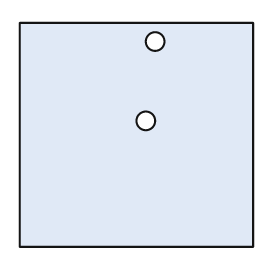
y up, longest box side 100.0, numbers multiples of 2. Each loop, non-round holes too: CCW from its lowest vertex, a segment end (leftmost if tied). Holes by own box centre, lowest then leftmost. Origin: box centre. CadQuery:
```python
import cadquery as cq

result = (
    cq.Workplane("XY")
    .moveTo(-50.0, -48.0)
    .lineTo(50.0, -48.0)
    .lineTo(50.0, 48.0)
    .lineTo(-50.0, 48.0)
    .close()
    .moveTo(4.0, 6.0)
    .circle(4.0)
    .moveTo(8.0, 40.0)
    .circle(4.0)
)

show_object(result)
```